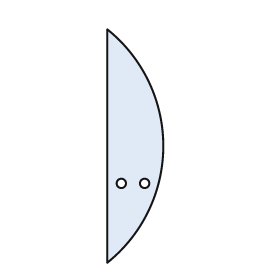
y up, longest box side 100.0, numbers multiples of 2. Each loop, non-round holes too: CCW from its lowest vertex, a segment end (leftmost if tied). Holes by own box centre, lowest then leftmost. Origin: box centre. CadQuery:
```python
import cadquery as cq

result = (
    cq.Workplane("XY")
    .moveTo(-12.0, -50.0)
    .threePointArc((12.0, 0.0), (-12.0, 50.0))
    .close()
    .moveTo(-6.0, -16.0)
    .circle(2.0)
    .moveTo(4.0, -16.0)
    .circle(2.0)
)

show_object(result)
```